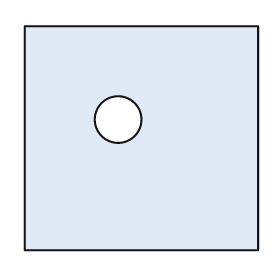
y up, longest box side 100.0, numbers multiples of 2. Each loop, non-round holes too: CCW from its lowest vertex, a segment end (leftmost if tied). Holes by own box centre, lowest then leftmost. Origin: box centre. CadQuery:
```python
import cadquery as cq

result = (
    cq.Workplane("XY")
    .moveTo(-50.0, -48.0)
    .lineTo(50.0, -48.0)
    .lineTo(50.0, 48.0)
    .lineTo(-50.0, 48.0)
    .close()
    .moveTo(-10.0, 8.0)
    .circle(10.0)
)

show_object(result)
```